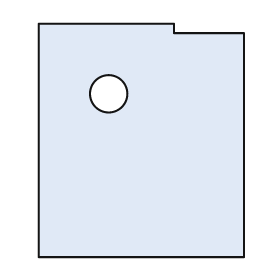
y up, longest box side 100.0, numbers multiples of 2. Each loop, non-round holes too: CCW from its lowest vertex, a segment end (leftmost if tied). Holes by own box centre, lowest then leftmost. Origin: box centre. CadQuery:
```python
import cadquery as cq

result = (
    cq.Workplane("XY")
    .moveTo(-44.0, -50.0)
    .lineTo(44.0, -50.0)
    .lineTo(44.0, 46.0)
    .lineTo(14.0, 46.0)
    .lineTo(14.0, 50.0)
    .lineTo(-44.0, 50.0)
    .close()
    .moveTo(-14.0, 20.0)
    .circle(8.0)
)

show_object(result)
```